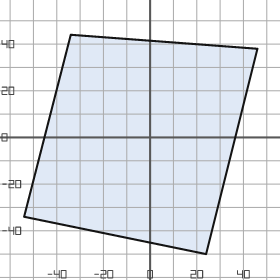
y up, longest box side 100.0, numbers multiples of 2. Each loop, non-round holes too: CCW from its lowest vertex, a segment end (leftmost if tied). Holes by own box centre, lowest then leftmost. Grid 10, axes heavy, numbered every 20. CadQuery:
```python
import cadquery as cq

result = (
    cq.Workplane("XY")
    .moveTo(24.0, -50.0)
    .lineTo(46.0, 38.0)
    .lineTo(-34.0, 44.0)
    .lineTo(-54.0, -34.0)
    .close()
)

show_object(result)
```